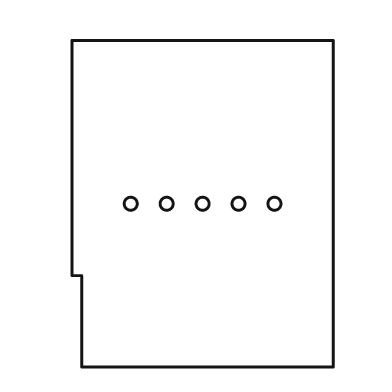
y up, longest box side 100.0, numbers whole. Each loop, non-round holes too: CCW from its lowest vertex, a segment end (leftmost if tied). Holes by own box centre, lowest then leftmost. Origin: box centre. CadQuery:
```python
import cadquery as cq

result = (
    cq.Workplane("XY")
    .moveTo(-37.0, -50.0)
    .lineTo(40.0, -50.0)
    .lineTo(40.0, 50.0)
    .lineTo(-40.0, 50.0)
    .lineTo(-40.0, -22.0)
    .lineTo(-37.0, -22.0)
    .close()
    .moveTo(-22.0, 0.0)
    .circle(2.0)
    .moveTo(-11.0, 0.0)
    .circle(2.0)
    .moveTo(0.0, 0.0)
    .circle(2.0)
    .moveTo(11.0, 0.0)
    .circle(2.0)
    .moveTo(22.0, 0.0)
    .circle(2.0)
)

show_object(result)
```